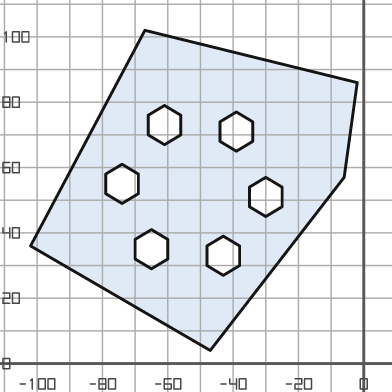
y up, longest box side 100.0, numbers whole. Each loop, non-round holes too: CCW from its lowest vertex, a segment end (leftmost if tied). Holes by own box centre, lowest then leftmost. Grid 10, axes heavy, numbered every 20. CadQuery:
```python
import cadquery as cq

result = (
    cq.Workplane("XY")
    .moveTo(-47.0, 4.0)
    .lineTo(-6.0, 57.0)
    .lineTo(-2.0, 86.0)
    .lineTo(-67.0, 102.0)
    .lineTo(-102.0, 36.0)
    .close()
    .moveTo(-43.0, 27.0)
    .lineTo(-38.0, 30.0)
    .lineTo(-38.0, 36.0)
    .lineTo(-43.0, 39.0)
    .lineTo(-48.0, 36.0)
    .lineTo(-48.0, 30.0)
    .close()
    .moveTo(-65.0, 29.0)
    .lineTo(-60.0, 32.0)
    .lineTo(-60.0, 38.0)
    .lineTo(-65.0, 41.0)
    .lineTo(-70.0, 38.0)
    .lineTo(-70.0, 32.0)
    .close()
    .moveTo(-30.0, 45.0)
    .lineTo(-25.0, 48.0)
    .lineTo(-25.0, 54.0)
    .lineTo(-30.0, 57.0)
    .lineTo(-35.0, 54.0)
    .lineTo(-35.0, 48.0)
    .close()
    .moveTo(-74.0, 49.0)
    .lineTo(-69.0, 52.0)
    .lineTo(-69.0, 58.0)
    .lineTo(-74.0, 61.0)
    .lineTo(-79.0, 58.0)
    .lineTo(-79.0, 52.0)
    .close()
    .moveTo(-39.0, 65.0)
    .lineTo(-34.0, 68.0)
    .lineTo(-34.0, 74.0)
    .lineTo(-39.0, 77.0)
    .lineTo(-44.0, 74.0)
    .lineTo(-44.0, 68.0)
    .close()
    .moveTo(-61.0, 67.0)
    .lineTo(-56.0, 70.0)
    .lineTo(-56.0, 76.0)
    .lineTo(-61.0, 79.0)
    .lineTo(-66.0, 76.0)
    .lineTo(-66.0, 70.0)
    .close()
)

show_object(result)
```